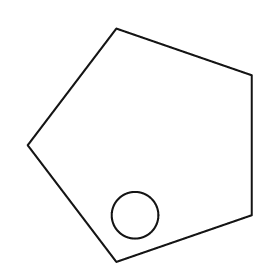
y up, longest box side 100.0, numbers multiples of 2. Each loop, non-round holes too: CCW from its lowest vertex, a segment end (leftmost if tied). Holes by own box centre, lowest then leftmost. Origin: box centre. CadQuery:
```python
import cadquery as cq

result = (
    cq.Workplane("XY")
    .moveTo(-10.0, -50.0)
    .lineTo(48.0, -30.0)
    .lineTo(48.0, 30.0)
    .lineTo(-10.0, 50.0)
    .lineTo(-48.0, 0.0)
    .close()
    .moveTo(-2.0, -30.0)
    .circle(10.0)
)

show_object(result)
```